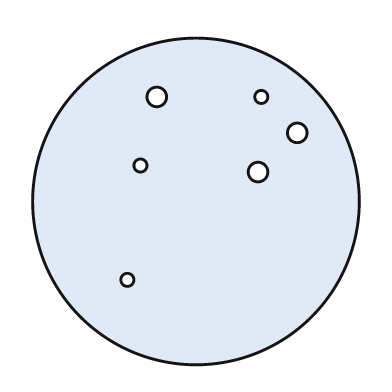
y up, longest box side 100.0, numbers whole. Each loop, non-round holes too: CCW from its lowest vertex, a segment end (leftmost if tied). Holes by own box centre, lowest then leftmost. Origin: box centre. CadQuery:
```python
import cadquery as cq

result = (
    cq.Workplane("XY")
    .moveTo(0.0, 0.0)
    .circle(50.0)
    .moveTo(-21.0, -24.0)
    .circle(2.0)
    .moveTo(19.0, 9.0)
    .circle(3.0)
    .moveTo(-17.0, 11.0)
    .circle(2.0)
    .moveTo(31.0, 21.0)
    .circle(3.0)
    .moveTo(-12.0, 32.0)
    .circle(3.0)
    .moveTo(20.0, 32.0)
    .circle(2.0)
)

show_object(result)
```